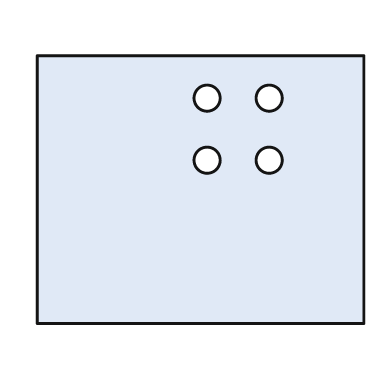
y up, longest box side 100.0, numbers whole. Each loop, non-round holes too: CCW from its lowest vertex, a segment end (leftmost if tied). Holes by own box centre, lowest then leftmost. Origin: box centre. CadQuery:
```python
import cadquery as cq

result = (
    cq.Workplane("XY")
    .moveTo(-50.0, -41.0)
    .lineTo(50.0, -41.0)
    .lineTo(50.0, 41.0)
    .lineTo(-50.0, 41.0)
    .close()
    .moveTo(2.0, 9.0)
    .circle(4.0)
    .moveTo(21.0, 9.0)
    .circle(4.0)
    .moveTo(2.0, 28.0)
    .circle(4.0)
    .moveTo(21.0, 28.0)
    .circle(4.0)
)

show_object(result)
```